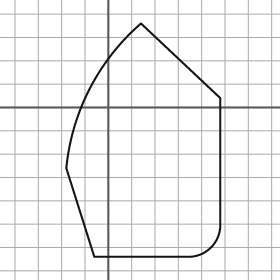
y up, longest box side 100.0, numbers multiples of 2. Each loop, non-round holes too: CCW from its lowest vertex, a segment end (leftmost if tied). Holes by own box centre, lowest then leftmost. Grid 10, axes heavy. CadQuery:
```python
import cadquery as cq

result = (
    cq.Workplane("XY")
    .moveTo(-6.0, -64.0)
    .lineTo(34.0, -64.0)
    .threePointArc((44.0, -60.0), (48.0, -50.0))
    .lineTo(48.0, 4.0)
    .lineTo(14.0, 36.0)
    .threePointArc((-8.0, 8.0), (-18.0, -26.0))
    .close()
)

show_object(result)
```